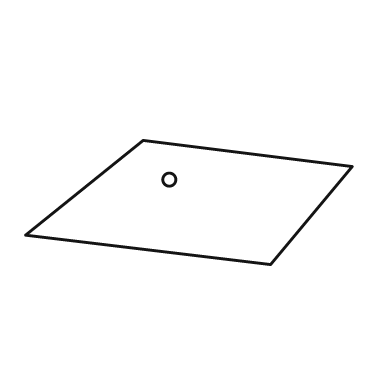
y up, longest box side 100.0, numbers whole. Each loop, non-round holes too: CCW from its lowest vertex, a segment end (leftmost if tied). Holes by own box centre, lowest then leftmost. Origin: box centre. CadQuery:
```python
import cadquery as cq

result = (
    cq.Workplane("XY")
    .moveTo(25.0, -19.0)
    .lineTo(50.0, 11.0)
    .lineTo(-14.0, 19.0)
    .lineTo(-50.0, -10.0)
    .close()
    .moveTo(-6.0, 7.0)
    .circle(2.0)
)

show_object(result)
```